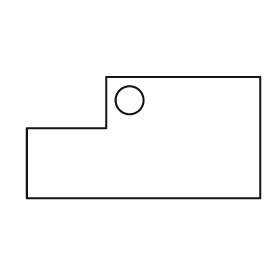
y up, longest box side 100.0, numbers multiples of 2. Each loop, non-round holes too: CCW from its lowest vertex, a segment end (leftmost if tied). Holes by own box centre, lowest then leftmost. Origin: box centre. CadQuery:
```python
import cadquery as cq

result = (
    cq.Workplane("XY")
    .moveTo(-50.0, -26.0)
    .lineTo(50.0, -26.0)
    .lineTo(50.0, 26.0)
    .lineTo(-16.0, 26.0)
    .lineTo(-16.0, 4.0)
    .lineTo(-50.0, 4.0)
    .close()
    .moveTo(-6.0, 16.0)
    .circle(6.0)
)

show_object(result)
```